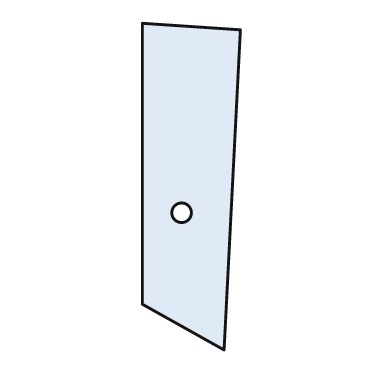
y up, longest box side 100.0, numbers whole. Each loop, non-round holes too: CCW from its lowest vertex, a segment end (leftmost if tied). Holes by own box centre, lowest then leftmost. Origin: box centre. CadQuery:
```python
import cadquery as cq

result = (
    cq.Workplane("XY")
    .moveTo(10.0, -50.0)
    .lineTo(15.0, 48.0)
    .lineTo(-15.0, 50.0)
    .lineTo(-15.0, -36.0)
    .close()
    .moveTo(-3.0, -8.0)
    .circle(3.0)
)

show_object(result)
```